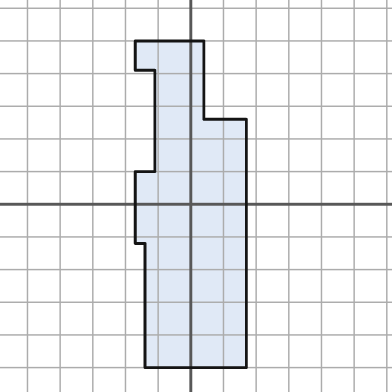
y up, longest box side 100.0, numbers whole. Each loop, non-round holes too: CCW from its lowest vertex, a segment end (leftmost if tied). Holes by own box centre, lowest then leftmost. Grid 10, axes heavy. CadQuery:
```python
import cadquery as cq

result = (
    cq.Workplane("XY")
    .moveTo(-14.0, -50.0)
    .lineTo(17.0, -50.0)
    .lineTo(17.0, 26.0)
    .lineTo(4.0, 26.0)
    .lineTo(4.0, 50.0)
    .lineTo(-17.0, 50.0)
    .lineTo(-17.0, 41.0)
    .lineTo(-11.0, 41.0)
    .lineTo(-11.0, 10.0)
    .lineTo(-17.0, 10.0)
    .lineTo(-17.0, -12.0)
    .lineTo(-14.0, -12.0)
    .close()
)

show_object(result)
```